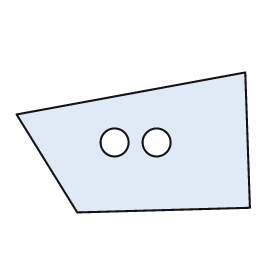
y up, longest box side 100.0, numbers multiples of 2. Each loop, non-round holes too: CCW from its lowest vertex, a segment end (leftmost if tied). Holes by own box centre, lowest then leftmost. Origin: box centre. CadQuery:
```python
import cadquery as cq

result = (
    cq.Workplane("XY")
    .moveTo(-24.0, -30.0)
    .lineTo(50.0, -28.0)
    .lineTo(48.0, 30.0)
    .lineTo(-50.0, 12.0)
    .close()
    .moveTo(-8.0, 0.0)
    .circle(6.0)
    .moveTo(10.0, 0.0)
    .circle(6.0)
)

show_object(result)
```